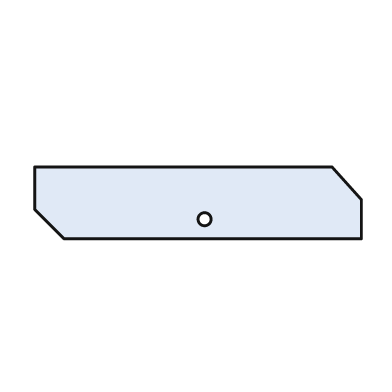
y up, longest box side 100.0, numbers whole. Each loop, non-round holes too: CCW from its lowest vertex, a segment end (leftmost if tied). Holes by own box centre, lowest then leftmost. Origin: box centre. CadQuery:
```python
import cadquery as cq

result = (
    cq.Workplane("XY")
    .moveTo(-41.0, -11.0)
    .lineTo(50.0, -11.0)
    .lineTo(50.0, 1.0)
    .lineTo(41.0, 11.0)
    .lineTo(-50.0, 11.0)
    .lineTo(-50.0, -2.0)
    .close()
    .moveTo(2.0, -5.0)
    .circle(2.0)
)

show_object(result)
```